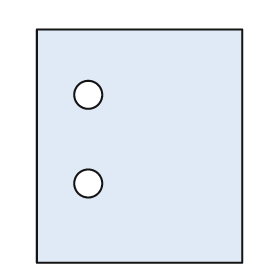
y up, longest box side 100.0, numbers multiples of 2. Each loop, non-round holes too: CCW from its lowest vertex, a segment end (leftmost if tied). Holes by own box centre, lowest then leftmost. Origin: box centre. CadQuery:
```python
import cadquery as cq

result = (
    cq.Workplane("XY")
    .moveTo(-44.0, -50.0)
    .lineTo(44.0, -50.0)
    .lineTo(44.0, 50.0)
    .lineTo(-44.0, 50.0)
    .close()
    .moveTo(-22.0, -16.0)
    .circle(6.0)
    .moveTo(-22.0, 22.0)
    .circle(6.0)
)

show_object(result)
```